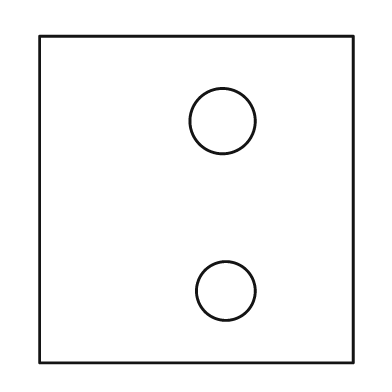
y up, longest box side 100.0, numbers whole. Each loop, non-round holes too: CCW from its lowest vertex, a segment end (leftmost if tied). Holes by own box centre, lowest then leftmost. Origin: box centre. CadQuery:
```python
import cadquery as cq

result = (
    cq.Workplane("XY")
    .moveTo(-48.0, -50.0)
    .lineTo(48.0, -50.0)
    .lineTo(48.0, 50.0)
    .lineTo(-48.0, 50.0)
    .close()
    .moveTo(9.0, -28.0)
    .circle(9.0)
    .moveTo(8.0, 24.0)
    .circle(10.0)
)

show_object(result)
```